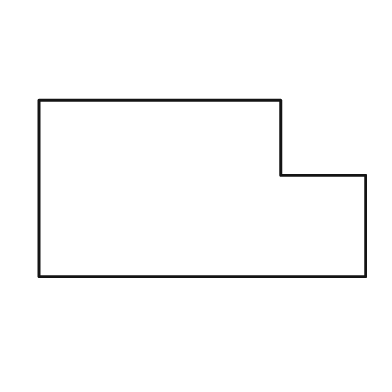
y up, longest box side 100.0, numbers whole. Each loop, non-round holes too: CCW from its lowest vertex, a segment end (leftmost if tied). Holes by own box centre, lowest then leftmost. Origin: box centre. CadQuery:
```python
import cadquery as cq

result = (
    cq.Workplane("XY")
    .moveTo(-50.0, -27.0)
    .lineTo(50.0, -27.0)
    .lineTo(50.0, 4.0)
    .lineTo(24.0, 4.0)
    .lineTo(24.0, 27.0)
    .lineTo(-50.0, 27.0)
    .close()
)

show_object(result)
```